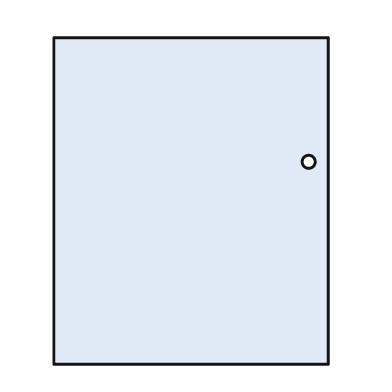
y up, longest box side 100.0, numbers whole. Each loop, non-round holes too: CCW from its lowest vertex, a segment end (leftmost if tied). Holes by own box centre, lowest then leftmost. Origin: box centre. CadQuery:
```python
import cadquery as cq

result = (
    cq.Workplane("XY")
    .moveTo(-42.0, -50.0)
    .lineTo(42.0, -50.0)
    .lineTo(42.0, 50.0)
    .lineTo(-42.0, 50.0)
    .close()
    .moveTo(36.0, 12.0)
    .circle(2.0)
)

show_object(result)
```